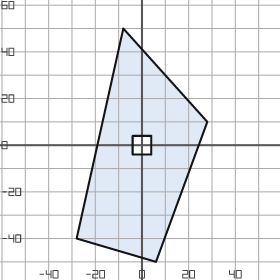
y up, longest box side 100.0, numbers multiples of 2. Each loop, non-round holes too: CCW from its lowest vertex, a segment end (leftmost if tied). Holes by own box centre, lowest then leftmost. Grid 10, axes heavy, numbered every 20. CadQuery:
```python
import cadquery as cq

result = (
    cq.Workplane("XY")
    .moveTo(6.0, -50.0)
    .lineTo(28.0, 10.0)
    .lineTo(-8.0, 50.0)
    .lineTo(-28.0, -40.0)
    .close()
    .moveTo(-4.0, -4.0)
    .lineTo(4.0, -4.0)
    .lineTo(4.0, 4.0)
    .lineTo(-4.0, 4.0)
    .close()
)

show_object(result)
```